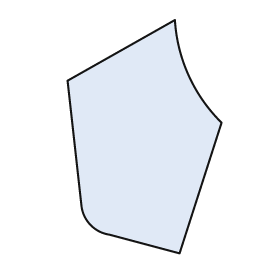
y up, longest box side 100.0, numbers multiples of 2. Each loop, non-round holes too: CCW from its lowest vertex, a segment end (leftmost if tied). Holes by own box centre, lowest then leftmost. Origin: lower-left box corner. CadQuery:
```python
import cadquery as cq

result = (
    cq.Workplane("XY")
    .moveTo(48.0, 0.0)
    .lineTo(66.0, 56.0)
    .threePointArc((52.0, 76.0), (46.0, 100.0))
    .lineTo(0.0, 74.0)
    .lineTo(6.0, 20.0)
    .threePointArc((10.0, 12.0), (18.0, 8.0))
    .close()
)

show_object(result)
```